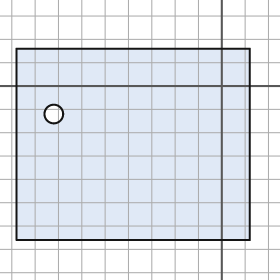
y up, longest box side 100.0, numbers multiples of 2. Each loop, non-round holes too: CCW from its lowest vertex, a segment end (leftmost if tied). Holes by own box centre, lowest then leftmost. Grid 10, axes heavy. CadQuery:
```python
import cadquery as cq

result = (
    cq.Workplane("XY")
    .moveTo(-88.0, -66.0)
    .lineTo(12.0, -66.0)
    .lineTo(12.0, 16.0)
    .lineTo(-88.0, 16.0)
    .close()
    .moveTo(-72.0, -12.0)
    .circle(4.0)
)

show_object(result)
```